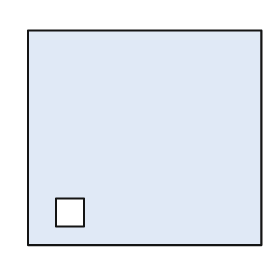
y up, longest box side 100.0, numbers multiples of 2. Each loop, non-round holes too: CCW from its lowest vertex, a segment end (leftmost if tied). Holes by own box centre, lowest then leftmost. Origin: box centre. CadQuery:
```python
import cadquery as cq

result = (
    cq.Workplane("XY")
    .moveTo(-50.0, -46.0)
    .lineTo(50.0, -46.0)
    .lineTo(50.0, 46.0)
    .lineTo(-50.0, 46.0)
    .close()
    .moveTo(-38.0, -38.0)
    .lineTo(-26.0, -38.0)
    .lineTo(-26.0, -26.0)
    .lineTo(-38.0, -26.0)
    .close()
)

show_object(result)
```